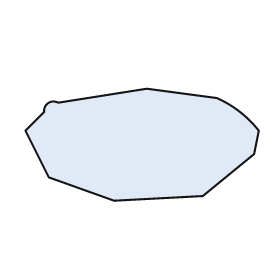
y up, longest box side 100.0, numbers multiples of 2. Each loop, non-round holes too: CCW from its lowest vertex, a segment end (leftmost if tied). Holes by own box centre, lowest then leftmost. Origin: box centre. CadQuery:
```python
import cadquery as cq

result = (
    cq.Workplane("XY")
    .moveTo(-12.0, -24.0)
    .lineTo(26.0, -22.0)
    .lineTo(48.0, -4.0)
    .lineTo(50.0, 6.0)
    .threePointArc((42.0, 14.0), (32.0, 20.0))
    .lineTo(2.0, 24.0)
    .lineTo(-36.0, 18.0)
    .threePointArc((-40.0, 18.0), (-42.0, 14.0))
    .lineTo(-50.0, 6.0)
    .lineTo(-40.0, -14.0)
    .close()
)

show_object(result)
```